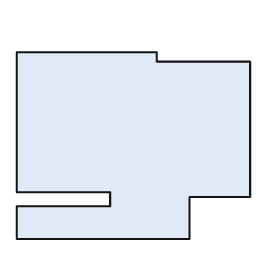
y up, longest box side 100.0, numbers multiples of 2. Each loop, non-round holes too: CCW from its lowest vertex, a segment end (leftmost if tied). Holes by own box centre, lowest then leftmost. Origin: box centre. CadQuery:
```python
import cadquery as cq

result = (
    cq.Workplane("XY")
    .moveTo(-50.0, -40.0)
    .lineTo(24.0, -40.0)
    .lineTo(24.0, -22.0)
    .lineTo(50.0, -22.0)
    .lineTo(50.0, 36.0)
    .lineTo(10.0, 36.0)
    .lineTo(10.0, 40.0)
    .lineTo(-50.0, 40.0)
    .lineTo(-50.0, -20.0)
    .lineTo(-10.0, -20.0)
    .lineTo(-10.0, -26.0)
    .lineTo(-50.0, -26.0)
    .close()
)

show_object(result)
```